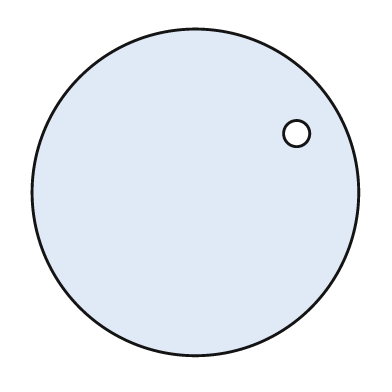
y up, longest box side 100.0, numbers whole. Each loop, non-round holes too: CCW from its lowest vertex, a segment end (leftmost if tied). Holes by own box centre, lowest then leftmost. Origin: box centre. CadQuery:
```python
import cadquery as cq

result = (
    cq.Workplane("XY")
    .moveTo(0.0, 0.0)
    .circle(50.0)
    .moveTo(31.0, 18.0)
    .circle(4.0)
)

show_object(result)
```